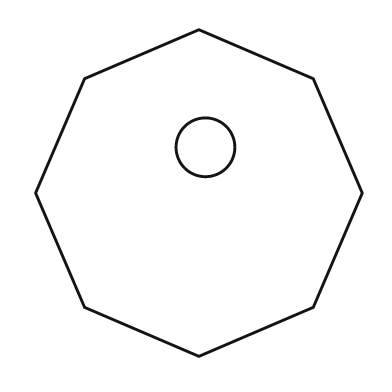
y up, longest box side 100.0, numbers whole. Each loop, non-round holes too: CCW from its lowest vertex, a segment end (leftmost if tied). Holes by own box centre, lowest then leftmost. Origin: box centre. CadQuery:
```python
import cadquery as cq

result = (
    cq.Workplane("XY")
    .moveTo(0.0, -50.0)
    .lineTo(35.0, -35.0)
    .lineTo(50.0, 0.0)
    .lineTo(35.0, 35.0)
    .lineTo(0.0, 50.0)
    .lineTo(-35.0, 35.0)
    .lineTo(-50.0, 0.0)
    .lineTo(-35.0, -35.0)
    .close()
    .moveTo(2.0, 14.0)
    .circle(9.0)
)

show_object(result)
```